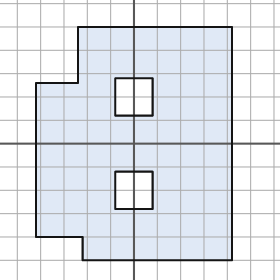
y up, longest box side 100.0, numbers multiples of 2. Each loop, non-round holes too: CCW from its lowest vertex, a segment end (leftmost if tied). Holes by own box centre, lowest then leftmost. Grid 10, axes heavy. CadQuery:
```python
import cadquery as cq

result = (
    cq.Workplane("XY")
    .moveTo(-22.0, -50.0)
    .lineTo(42.0, -50.0)
    .lineTo(42.0, 50.0)
    .lineTo(-24.0, 50.0)
    .lineTo(-24.0, 26.0)
    .lineTo(-42.0, 26.0)
    .lineTo(-42.0, -40.0)
    .lineTo(-22.0, -40.0)
    .close()
    .moveTo(-8.0, -28.0)
    .lineTo(8.0, -28.0)
    .lineTo(8.0, -12.0)
    .lineTo(-8.0, -12.0)
    .close()
    .moveTo(-8.0, 12.0)
    .lineTo(8.0, 12.0)
    .lineTo(8.0, 28.0)
    .lineTo(-8.0, 28.0)
    .close()
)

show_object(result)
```